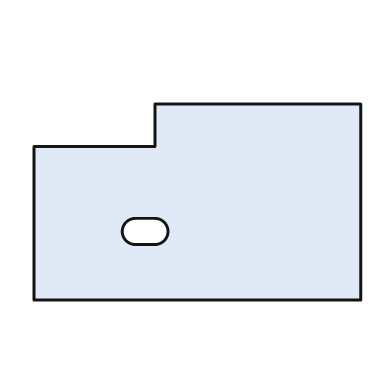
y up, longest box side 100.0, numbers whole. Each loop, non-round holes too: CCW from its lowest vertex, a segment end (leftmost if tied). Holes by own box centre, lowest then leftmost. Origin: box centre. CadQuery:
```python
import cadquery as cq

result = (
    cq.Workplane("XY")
    .moveTo(-50.0, -30.0)
    .lineTo(50.0, -30.0)
    .lineTo(50.0, 30.0)
    .lineTo(-13.0, 30.0)
    .lineTo(-13.0, 17.0)
    .lineTo(-50.0, 17.0)
    .close()
    .moveTo(-19.0, -13.0)
    .lineTo(-13.0, -13.0)
    .threePointArc((-9.0, -9.0), (-13.0, -5.0))
    .lineTo(-19.0, -5.0)
    .threePointArc((-23.0, -9.0), (-19.0, -13.0))
    .close()
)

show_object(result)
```